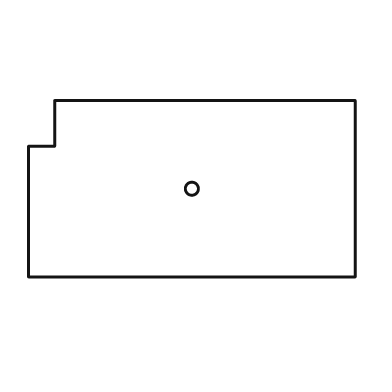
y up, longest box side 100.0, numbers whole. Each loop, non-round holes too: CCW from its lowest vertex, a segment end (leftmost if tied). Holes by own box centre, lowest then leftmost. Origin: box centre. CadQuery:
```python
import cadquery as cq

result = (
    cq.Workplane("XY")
    .moveTo(-50.0, -27.0)
    .lineTo(50.0, -27.0)
    .lineTo(50.0, 27.0)
    .lineTo(-42.0, 27.0)
    .lineTo(-42.0, 13.0)
    .lineTo(-50.0, 13.0)
    .close()
    .moveTo(0.0, 0.0)
    .circle(2.0)
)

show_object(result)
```